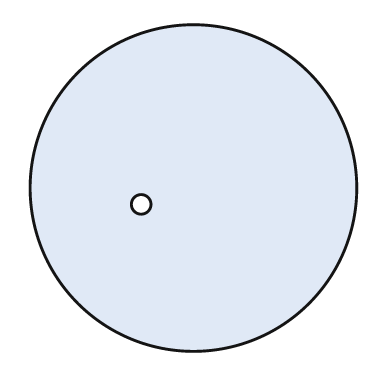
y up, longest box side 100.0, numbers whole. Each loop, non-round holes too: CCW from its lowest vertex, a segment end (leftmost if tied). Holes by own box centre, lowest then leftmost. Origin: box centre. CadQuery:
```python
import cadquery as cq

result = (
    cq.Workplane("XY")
    .moveTo(0.0, 0.0)
    .circle(50.0)
    .moveTo(-16.0, -5.0)
    .circle(3.0)
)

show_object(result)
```